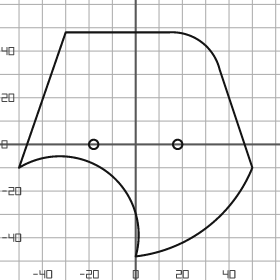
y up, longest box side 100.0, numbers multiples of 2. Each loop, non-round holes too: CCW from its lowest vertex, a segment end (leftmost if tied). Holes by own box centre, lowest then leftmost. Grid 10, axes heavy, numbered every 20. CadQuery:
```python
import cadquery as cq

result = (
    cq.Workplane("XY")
    .moveTo(0.0, -48.0)
    .threePointArc((30.0, -36.0), (50.0, -10.0))
    .lineTo(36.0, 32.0)
    .threePointArc((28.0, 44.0), (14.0, 48.0))
    .lineTo(-30.0, 48.0)
    .lineTo(-50.0, -10.0)
    .threePointArc((-12.0, -12.0), (0.0, -48.0))
    .close()
    .moveTo(-18.0, 0.0)
    .circle(2.0)
    .moveTo(18.0, 0.0)
    .circle(2.0)
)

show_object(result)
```